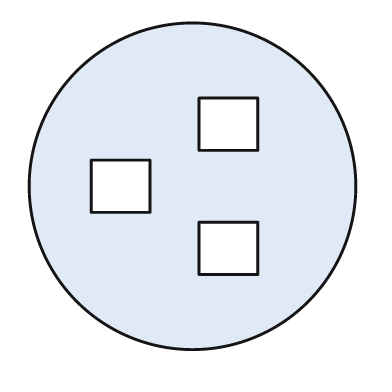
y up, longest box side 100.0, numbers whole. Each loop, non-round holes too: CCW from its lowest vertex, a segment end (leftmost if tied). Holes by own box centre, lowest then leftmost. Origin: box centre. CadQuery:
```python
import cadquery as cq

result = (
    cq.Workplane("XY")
    .moveTo(0.0, 0.0)
    .circle(50.0)
    .moveTo(2.0, -27.0)
    .lineTo(20.0, -27.0)
    .lineTo(20.0, -11.0)
    .lineTo(2.0, -11.0)
    .close()
    .moveTo(-31.0, -8.0)
    .lineTo(-13.0, -8.0)
    .lineTo(-13.0, 8.0)
    .lineTo(-31.0, 8.0)
    .close()
    .moveTo(2.0, 11.0)
    .lineTo(20.0, 11.0)
    .lineTo(20.0, 27.0)
    .lineTo(2.0, 27.0)
    .close()
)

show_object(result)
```